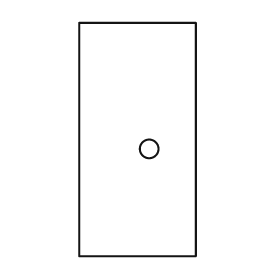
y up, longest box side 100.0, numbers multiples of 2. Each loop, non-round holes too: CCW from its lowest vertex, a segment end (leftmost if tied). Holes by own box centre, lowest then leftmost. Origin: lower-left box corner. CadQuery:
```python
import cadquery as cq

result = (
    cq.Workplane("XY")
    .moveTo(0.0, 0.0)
    .lineTo(50.0, 0.0)
    .lineTo(50.0, 100.0)
    .lineTo(0.0, 100.0)
    .close()
    .moveTo(30.0, 46.0)
    .circle(4.0)
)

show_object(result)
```